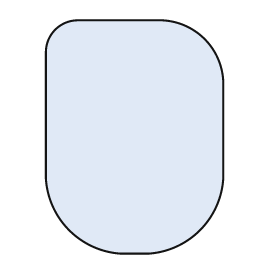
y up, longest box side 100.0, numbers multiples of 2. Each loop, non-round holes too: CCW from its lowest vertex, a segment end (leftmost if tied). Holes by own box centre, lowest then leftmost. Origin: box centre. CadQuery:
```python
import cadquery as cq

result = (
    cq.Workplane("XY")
    .moveTo(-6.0, -50.0)
    .lineTo(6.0, -50.0)
    .threePointArc((28.0, -40.0), (38.0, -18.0))
    .lineTo(38.0, 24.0)
    .threePointArc((30.0, 42.0), (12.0, 50.0))
    .lineTo(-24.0, 50.0)
    .threePointArc((-34.0, 46.0), (-38.0, 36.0))
    .lineTo(-38.0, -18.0)
    .threePointArc((-28.0, -40.0), (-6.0, -50.0))
    .close()
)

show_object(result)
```